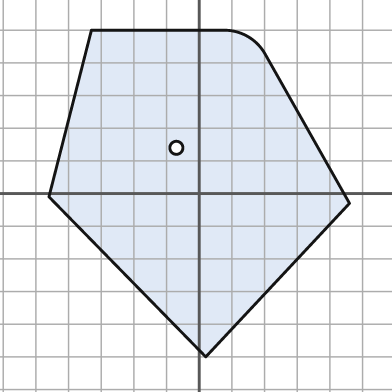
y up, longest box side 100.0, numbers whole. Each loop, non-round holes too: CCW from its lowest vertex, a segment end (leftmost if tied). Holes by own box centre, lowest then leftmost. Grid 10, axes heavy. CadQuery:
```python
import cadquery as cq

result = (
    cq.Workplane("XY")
    .moveTo(2.0, -50.0)
    .lineTo(46.0, -3.0)
    .lineTo(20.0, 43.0)
    .threePointArc((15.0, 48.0), (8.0, 50.0))
    .lineTo(-33.0, 50.0)
    .lineTo(-46.0, -1.0)
    .close()
    .moveTo(-7.0, 14.0)
    .circle(2.0)
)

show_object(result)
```